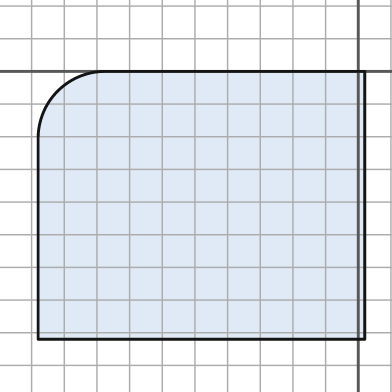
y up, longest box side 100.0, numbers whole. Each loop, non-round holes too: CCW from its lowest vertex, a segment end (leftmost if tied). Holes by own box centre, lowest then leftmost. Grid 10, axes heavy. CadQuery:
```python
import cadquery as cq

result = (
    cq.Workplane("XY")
    .moveTo(-98.0, -82.0)
    .lineTo(2.0, -82.0)
    .lineTo(2.0, 0.0)
    .lineTo(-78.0, 0.0)
    .threePointArc((-92.0, -6.0), (-98.0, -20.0))
    .close()
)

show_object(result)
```